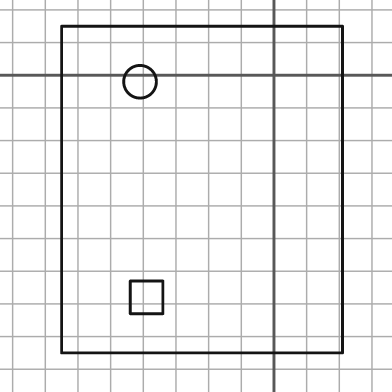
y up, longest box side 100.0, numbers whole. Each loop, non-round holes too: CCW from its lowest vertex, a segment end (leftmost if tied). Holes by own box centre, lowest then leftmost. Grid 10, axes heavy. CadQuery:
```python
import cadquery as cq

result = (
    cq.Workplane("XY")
    .moveTo(-65.0, -85.0)
    .lineTo(21.0, -85.0)
    .lineTo(21.0, 15.0)
    .lineTo(-65.0, 15.0)
    .close()
    .moveTo(-44.0, -73.0)
    .lineTo(-34.0, -73.0)
    .lineTo(-34.0, -63.0)
    .lineTo(-44.0, -63.0)
    .close()
    .moveTo(-41.0, -2.0)
    .circle(5.0)
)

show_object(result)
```